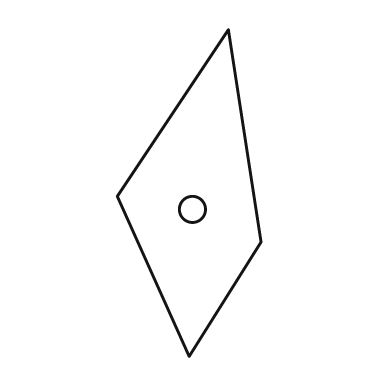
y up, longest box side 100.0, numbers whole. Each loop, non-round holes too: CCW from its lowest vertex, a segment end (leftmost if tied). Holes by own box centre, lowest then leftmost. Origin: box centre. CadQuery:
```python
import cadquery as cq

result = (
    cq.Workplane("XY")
    .moveTo(0.0, -50.0)
    .lineTo(22.0, -15.0)
    .lineTo(12.0, 50.0)
    .lineTo(-22.0, -1.0)
    .close()
    .moveTo(1.0, -5.0)
    .circle(4.0)
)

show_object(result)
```